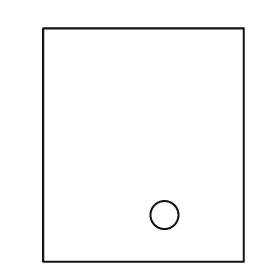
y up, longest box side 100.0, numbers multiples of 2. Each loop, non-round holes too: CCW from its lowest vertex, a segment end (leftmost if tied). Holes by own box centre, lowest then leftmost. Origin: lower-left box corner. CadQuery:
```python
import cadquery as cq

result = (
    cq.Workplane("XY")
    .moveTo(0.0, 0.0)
    .lineTo(86.0, 0.0)
    .lineTo(86.0, 100.0)
    .lineTo(0.0, 100.0)
    .close()
    .moveTo(52.0, 20.0)
    .circle(6.0)
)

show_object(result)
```